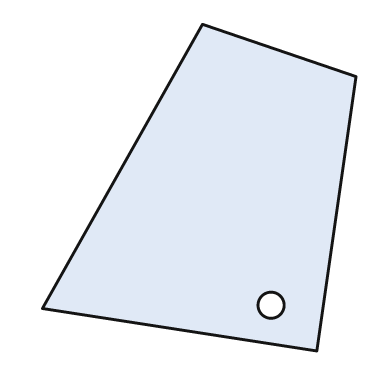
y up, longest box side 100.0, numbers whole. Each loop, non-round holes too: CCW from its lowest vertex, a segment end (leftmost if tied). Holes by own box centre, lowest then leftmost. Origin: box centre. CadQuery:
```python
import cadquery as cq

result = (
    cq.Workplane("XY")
    .moveTo(36.0, -50.0)
    .lineTo(48.0, 34.0)
    .lineTo(1.0, 50.0)
    .lineTo(-48.0, -37.0)
    .close()
    .moveTo(22.0, -36.0)
    .circle(4.0)
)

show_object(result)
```